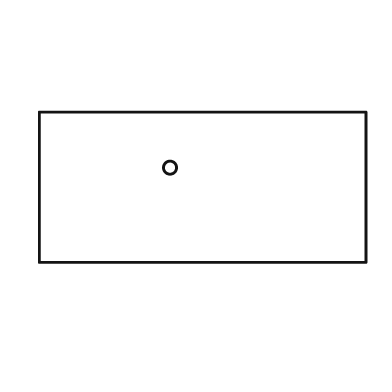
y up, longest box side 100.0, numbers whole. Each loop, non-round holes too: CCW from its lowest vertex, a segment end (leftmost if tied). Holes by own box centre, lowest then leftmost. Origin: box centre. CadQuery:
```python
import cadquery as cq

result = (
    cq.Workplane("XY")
    .moveTo(-50.0, -23.0)
    .lineTo(50.0, -23.0)
    .lineTo(50.0, 23.0)
    .lineTo(-50.0, 23.0)
    .close()
    .moveTo(-10.0, 6.0)
    .circle(2.0)
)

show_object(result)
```